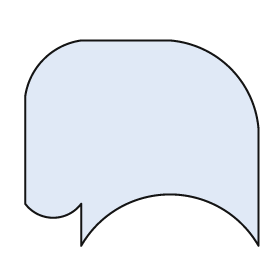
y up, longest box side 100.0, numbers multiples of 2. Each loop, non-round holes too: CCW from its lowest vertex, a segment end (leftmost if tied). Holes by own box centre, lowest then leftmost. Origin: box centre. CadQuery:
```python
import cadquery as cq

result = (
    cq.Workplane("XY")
    .moveTo(-26.0, -44.0)
    .threePointArc((12.0, -22.0), (50.0, -44.0))
    .lineTo(50.0, 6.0)
    .threePointArc((38.0, 32.0), (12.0, 44.0))
    .lineTo(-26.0, 44.0)
    .threePointArc((-42.0, 36.0), (-50.0, 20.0))
    .lineTo(-50.0, -26.0)
    .threePointArc((-38.0, -32.0), (-26.0, -26.0))
    .close()
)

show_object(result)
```